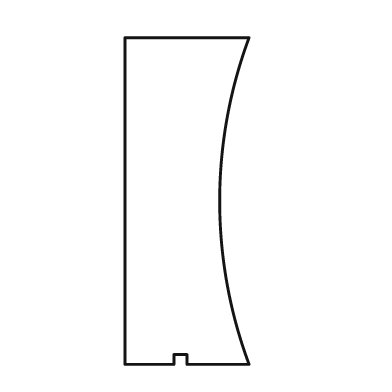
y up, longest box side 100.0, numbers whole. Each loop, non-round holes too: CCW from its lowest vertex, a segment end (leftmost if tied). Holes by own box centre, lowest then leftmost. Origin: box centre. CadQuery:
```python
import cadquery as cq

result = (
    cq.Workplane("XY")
    .moveTo(-19.0, -50.0)
    .lineTo(-4.0, -50.0)
    .lineTo(-4.0, -47.0)
    .lineTo(0.0, -47.0)
    .lineTo(0.0, -50.0)
    .lineTo(19.0, -50.0)
    .threePointArc((10.0, 0.0), (19.0, 50.0))
    .lineTo(-19.0, 50.0)
    .close()
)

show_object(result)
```